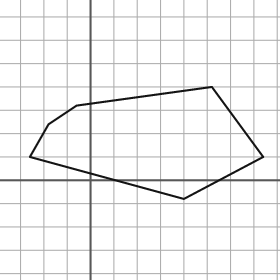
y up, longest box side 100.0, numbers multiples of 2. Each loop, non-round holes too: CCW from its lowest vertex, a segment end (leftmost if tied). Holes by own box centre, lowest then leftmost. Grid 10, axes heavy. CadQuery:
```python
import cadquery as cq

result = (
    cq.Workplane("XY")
    .moveTo(40.0, -8.0)
    .lineTo(74.0, 10.0)
    .lineTo(52.0, 40.0)
    .lineTo(-6.0, 32.0)
    .lineTo(-18.0, 24.0)
    .lineTo(-26.0, 10.0)
    .close()
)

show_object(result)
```